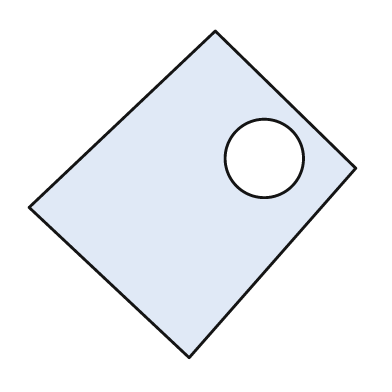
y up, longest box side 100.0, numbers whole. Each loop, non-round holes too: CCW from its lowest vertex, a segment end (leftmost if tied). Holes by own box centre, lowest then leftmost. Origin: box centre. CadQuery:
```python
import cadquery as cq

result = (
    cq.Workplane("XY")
    .moveTo(-1.0, -50.0)
    .lineTo(50.0, 8.0)
    .lineTo(7.0, 50.0)
    .lineTo(-50.0, -4.0)
    .close()
    .moveTo(22.0, 11.0)
    .circle(12.0)
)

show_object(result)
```